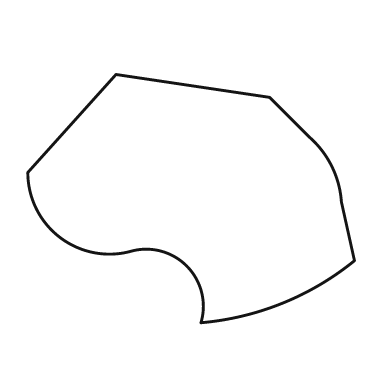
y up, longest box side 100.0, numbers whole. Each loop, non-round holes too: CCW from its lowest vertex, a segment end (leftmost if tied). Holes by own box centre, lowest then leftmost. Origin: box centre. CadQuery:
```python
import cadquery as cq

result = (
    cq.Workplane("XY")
    .moveTo(3.0, -38.0)
    .threePointArc((28.0, -32.0), (50.0, -19.0))
    .lineTo(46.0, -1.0)
    .threePointArc((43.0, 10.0), (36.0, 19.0))
    .lineTo(24.0, 31.0)
    .lineTo(-23.0, 38.0)
    .lineTo(-50.0, 8.0)
    .threePointArc((-40.0, -12.0), (-18.0, -16.0))
    .threePointArc((-1.0, -21.0), (3.0, -38.0))
    .close()
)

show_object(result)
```